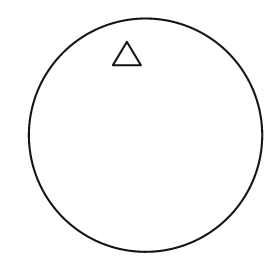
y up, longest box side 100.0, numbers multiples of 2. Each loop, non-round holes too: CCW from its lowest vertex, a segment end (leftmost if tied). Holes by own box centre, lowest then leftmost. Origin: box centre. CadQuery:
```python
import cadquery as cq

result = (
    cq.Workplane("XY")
    .moveTo(0.0, 0.0)
    .circle(50.0)
    .moveTo(-14.0, 30.0)
    .lineTo(-2.0, 30.0)
    .lineTo(-8.0, 40.0)
    .close()
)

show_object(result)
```